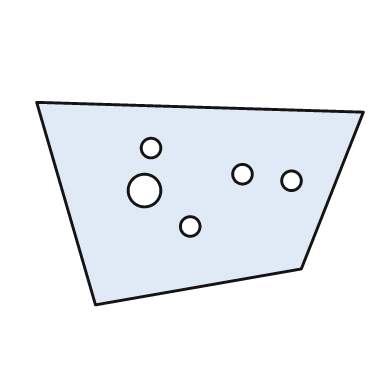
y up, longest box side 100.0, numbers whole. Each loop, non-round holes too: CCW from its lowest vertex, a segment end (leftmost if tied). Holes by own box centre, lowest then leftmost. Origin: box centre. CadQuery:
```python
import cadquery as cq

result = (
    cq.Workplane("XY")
    .moveTo(-32.0, -31.0)
    .lineTo(31.0, -20.0)
    .lineTo(50.0, 28.0)
    .lineTo(-50.0, 31.0)
    .close()
    .moveTo(-3.0, -7.0)
    .circle(3.0)
    .moveTo(-17.0, 4.0)
    .circle(5.0)
    .moveTo(28.0, 7.0)
    .circle(3.0)
    .moveTo(13.0, 9.0)
    .circle(3.0)
    .moveTo(-15.0, 17.0)
    .circle(3.0)
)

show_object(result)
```